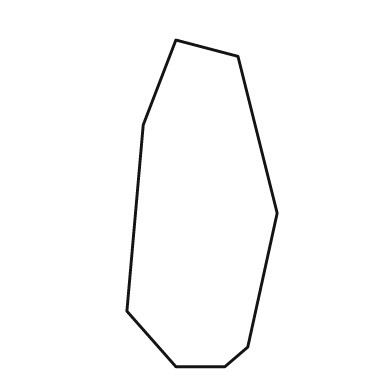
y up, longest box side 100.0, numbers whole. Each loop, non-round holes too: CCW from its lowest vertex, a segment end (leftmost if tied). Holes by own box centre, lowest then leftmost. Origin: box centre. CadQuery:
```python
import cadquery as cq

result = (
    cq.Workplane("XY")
    .moveTo(-8.0, -50.0)
    .lineTo(7.0, -50.0)
    .lineTo(14.0, -44.0)
    .lineTo(23.0, -3.0)
    .lineTo(11.0, 45.0)
    .lineTo(-8.0, 50.0)
    .lineTo(-18.0, 24.0)
    .lineTo(-23.0, -33.0)
    .close()
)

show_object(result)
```